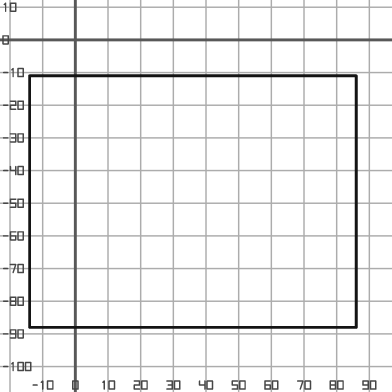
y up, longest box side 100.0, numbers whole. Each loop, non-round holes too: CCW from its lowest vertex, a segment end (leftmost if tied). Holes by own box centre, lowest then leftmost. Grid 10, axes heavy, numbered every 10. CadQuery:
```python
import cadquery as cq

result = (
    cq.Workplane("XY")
    .moveTo(-14.0, -88.0)
    .lineTo(86.0, -88.0)
    .lineTo(86.0, -11.0)
    .lineTo(-14.0, -11.0)
    .close()
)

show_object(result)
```